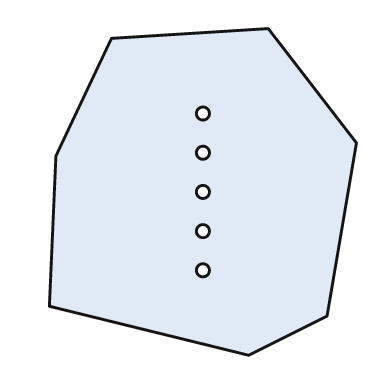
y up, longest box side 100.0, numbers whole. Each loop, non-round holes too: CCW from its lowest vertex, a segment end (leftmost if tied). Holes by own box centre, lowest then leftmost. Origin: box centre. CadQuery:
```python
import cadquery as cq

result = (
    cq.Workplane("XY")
    .moveTo(14.0, -50.0)
    .lineTo(38.0, -38.0)
    .lineTo(47.0, 15.0)
    .lineTo(20.0, 50.0)
    .lineTo(-28.0, 47.0)
    .lineTo(-45.0, 11.0)
    .lineTo(-47.0, -35.0)
    .close()
    .moveTo(0.0, -24.0)
    .circle(2.0)
    .moveTo(0.0, -12.0)
    .circle(2.0)
    .moveTo(0.0, 0.0)
    .circle(2.0)
    .moveTo(0.0, 12.0)
    .circle(2.0)
    .moveTo(0.0, 24.0)
    .circle(2.0)
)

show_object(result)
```